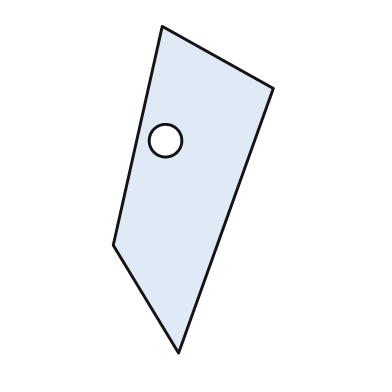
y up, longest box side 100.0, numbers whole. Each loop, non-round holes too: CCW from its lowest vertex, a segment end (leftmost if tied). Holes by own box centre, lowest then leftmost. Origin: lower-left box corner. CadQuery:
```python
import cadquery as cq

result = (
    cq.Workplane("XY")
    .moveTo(20.0, 0.0)
    .lineTo(49.0, 81.0)
    .lineTo(15.0, 100.0)
    .lineTo(0.0, 33.0)
    .close()
    .moveTo(16.0, 65.0)
    .circle(5.0)
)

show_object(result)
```